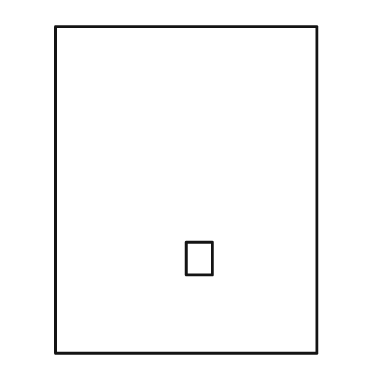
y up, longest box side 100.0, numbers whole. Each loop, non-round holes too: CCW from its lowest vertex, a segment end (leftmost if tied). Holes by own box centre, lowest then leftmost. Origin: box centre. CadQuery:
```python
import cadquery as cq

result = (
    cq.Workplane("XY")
    .moveTo(-40.0, -50.0)
    .lineTo(40.0, -50.0)
    .lineTo(40.0, 50.0)
    .lineTo(-40.0, 50.0)
    .close()
    .moveTo(0.0, -26.0)
    .lineTo(8.0, -26.0)
    .lineTo(8.0, -16.0)
    .lineTo(0.0, -16.0)
    .close()
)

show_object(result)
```